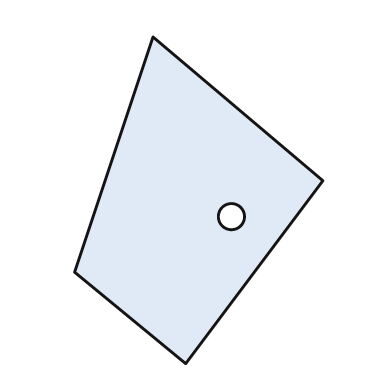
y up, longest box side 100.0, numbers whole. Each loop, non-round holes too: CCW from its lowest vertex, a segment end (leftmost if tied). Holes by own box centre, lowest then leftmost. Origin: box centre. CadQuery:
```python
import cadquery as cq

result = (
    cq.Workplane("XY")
    .moveTo(-4.0, -50.0)
    .lineTo(38.0, 6.0)
    .lineTo(-14.0, 50.0)
    .lineTo(-38.0, -22.0)
    .close()
    .moveTo(10.0, -5.0)
    .circle(4.0)
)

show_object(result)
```